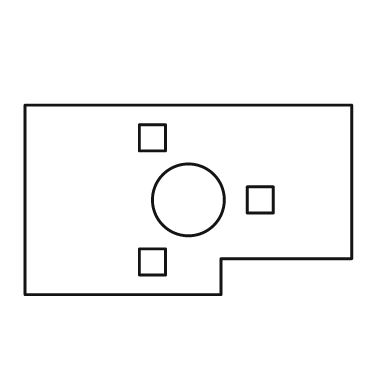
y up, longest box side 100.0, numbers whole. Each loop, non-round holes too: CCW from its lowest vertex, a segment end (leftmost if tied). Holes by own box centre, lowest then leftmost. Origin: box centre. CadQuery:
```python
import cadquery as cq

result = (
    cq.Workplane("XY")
    .moveTo(-50.0, -29.0)
    .lineTo(10.0, -29.0)
    .lineTo(10.0, -18.0)
    .lineTo(50.0, -18.0)
    .lineTo(50.0, 29.0)
    .lineTo(-50.0, 29.0)
    .close()
    .moveTo(-15.0, -23.0)
    .lineTo(-7.0, -23.0)
    .lineTo(-7.0, -15.0)
    .lineTo(-15.0, -15.0)
    .close()
    .moveTo(0.0, 0.0)
    .circle(11.0)
    .moveTo(18.0, -4.0)
    .lineTo(26.0, -4.0)
    .lineTo(26.0, 4.0)
    .lineTo(18.0, 4.0)
    .close()
    .moveTo(-15.0, 15.0)
    .lineTo(-7.0, 15.0)
    .lineTo(-7.0, 23.0)
    .lineTo(-15.0, 23.0)
    .close()
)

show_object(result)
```